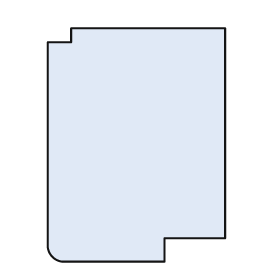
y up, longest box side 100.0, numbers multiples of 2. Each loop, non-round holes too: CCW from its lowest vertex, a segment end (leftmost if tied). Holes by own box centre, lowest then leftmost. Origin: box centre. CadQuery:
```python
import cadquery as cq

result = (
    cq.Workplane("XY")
    .moveTo(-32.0, -50.0)
    .lineTo(12.0, -50.0)
    .lineTo(12.0, -40.0)
    .lineTo(38.0, -40.0)
    .lineTo(38.0, 50.0)
    .lineTo(-28.0, 50.0)
    .lineTo(-28.0, 44.0)
    .lineTo(-38.0, 44.0)
    .lineTo(-38.0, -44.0)
    .threePointArc((-36.0, -48.0), (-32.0, -50.0))
    .close()
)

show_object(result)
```